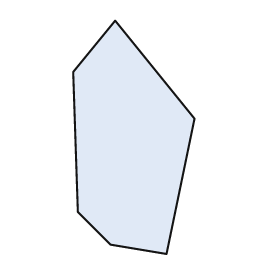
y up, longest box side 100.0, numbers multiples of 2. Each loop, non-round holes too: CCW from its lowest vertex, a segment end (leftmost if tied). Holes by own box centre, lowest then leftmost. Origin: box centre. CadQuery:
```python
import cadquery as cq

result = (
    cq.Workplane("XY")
    .moveTo(14.0, -50.0)
    .lineTo(26.0, 8.0)
    .lineTo(-8.0, 50.0)
    .lineTo(-26.0, 28.0)
    .lineTo(-24.0, -32.0)
    .lineTo(-10.0, -46.0)
    .close()
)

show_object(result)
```